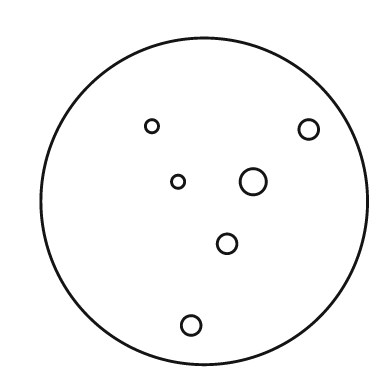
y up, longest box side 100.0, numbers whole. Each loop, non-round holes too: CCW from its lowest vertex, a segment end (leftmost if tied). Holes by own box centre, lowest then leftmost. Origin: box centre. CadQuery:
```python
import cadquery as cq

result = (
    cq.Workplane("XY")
    .moveTo(0.0, 0.0)
    .circle(50.0)
    .moveTo(-4.0, -38.0)
    .circle(3.0)
    .moveTo(7.0, -13.0)
    .circle(3.0)
    .moveTo(-8.0, 6.0)
    .circle(2.0)
    .moveTo(15.0, 6.0)
    .circle(4.0)
    .moveTo(32.0, 22.0)
    .circle(3.0)
    .moveTo(-16.0, 23.0)
    .circle(2.0)
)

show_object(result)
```